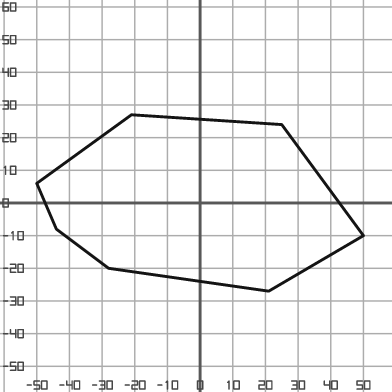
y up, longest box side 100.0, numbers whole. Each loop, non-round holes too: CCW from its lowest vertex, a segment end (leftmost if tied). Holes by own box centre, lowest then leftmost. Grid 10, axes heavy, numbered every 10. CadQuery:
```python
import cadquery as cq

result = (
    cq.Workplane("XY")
    .moveTo(21.0, -27.0)
    .lineTo(50.0, -10.0)
    .lineTo(25.0, 24.0)
    .lineTo(-21.0, 27.0)
    .lineTo(-50.0, 6.0)
    .lineTo(-44.0, -8.0)
    .lineTo(-28.0, -20.0)
    .close()
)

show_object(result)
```